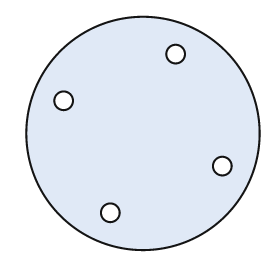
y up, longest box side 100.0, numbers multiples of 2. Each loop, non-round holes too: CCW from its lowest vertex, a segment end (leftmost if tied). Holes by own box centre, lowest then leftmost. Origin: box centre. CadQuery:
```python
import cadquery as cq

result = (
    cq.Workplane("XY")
    .moveTo(0.0, 0.0)
    .circle(50.0)
    .moveTo(-14.0, -34.0)
    .circle(4.0)
    .moveTo(34.0, -14.0)
    .circle(4.0)
    .moveTo(-34.0, 14.0)
    .circle(4.0)
    .moveTo(14.0, 34.0)
    .circle(4.0)
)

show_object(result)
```